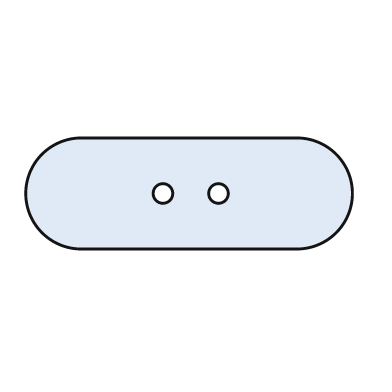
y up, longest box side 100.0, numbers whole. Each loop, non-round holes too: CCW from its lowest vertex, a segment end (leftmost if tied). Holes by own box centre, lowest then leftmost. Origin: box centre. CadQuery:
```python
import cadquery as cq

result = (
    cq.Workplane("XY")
    .moveTo(-33.0, -17.0)
    .lineTo(33.0, -17.0)
    .threePointArc((50.0, 0.0), (33.0, 17.0))
    .lineTo(-33.0, 17.0)
    .threePointArc((-50.0, 0.0), (-33.0, -17.0))
    .close()
    .moveTo(-8.0, 0.0)
    .circle(3.0)
    .moveTo(9.0, 0.0)
    .circle(3.0)
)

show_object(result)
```